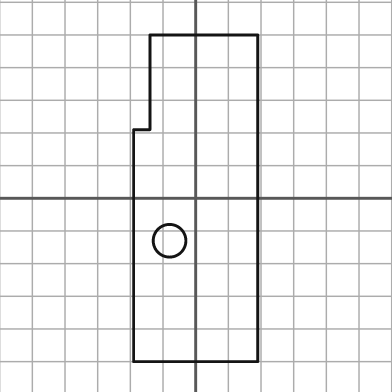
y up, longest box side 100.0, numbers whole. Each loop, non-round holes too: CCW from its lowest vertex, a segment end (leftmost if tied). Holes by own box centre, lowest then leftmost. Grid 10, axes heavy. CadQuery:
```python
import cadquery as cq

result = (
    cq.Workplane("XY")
    .moveTo(-19.0, -50.0)
    .lineTo(19.0, -50.0)
    .lineTo(19.0, 50.0)
    .lineTo(-14.0, 50.0)
    .lineTo(-14.0, 21.0)
    .lineTo(-19.0, 21.0)
    .close()
    .moveTo(-8.0, -13.0)
    .circle(5.0)
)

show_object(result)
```